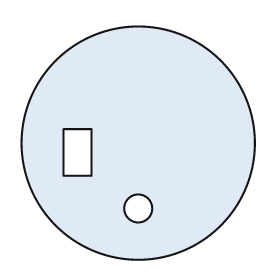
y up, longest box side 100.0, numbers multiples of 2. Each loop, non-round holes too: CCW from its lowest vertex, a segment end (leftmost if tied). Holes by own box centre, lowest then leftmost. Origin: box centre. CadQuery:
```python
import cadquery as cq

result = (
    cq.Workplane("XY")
    .moveTo(0.0, 0.0)
    .circle(50.0)
    .moveTo(0.0, -28.0)
    .circle(6.0)
    .moveTo(-32.0, -14.0)
    .lineTo(-20.0, -14.0)
    .lineTo(-20.0, 6.0)
    .lineTo(-32.0, 6.0)
    .close()
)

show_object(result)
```